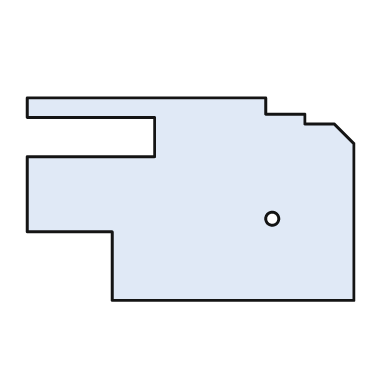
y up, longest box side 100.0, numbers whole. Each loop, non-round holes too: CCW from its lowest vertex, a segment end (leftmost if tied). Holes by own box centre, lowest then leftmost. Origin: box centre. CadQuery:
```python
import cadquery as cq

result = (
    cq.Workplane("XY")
    .moveTo(-24.0, -31.0)
    .lineTo(50.0, -31.0)
    .lineTo(50.0, 17.0)
    .lineTo(44.0, 23.0)
    .lineTo(35.0, 23.0)
    .lineTo(35.0, 26.0)
    .lineTo(23.0, 26.0)
    .lineTo(23.0, 31.0)
    .lineTo(-50.0, 31.0)
    .lineTo(-50.0, 25.0)
    .lineTo(-11.0, 25.0)
    .lineTo(-11.0, 13.0)
    .lineTo(-50.0, 13.0)
    .lineTo(-50.0, -10.0)
    .lineTo(-24.0, -10.0)
    .close()
    .moveTo(25.0, -6.0)
    .circle(2.0)
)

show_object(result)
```